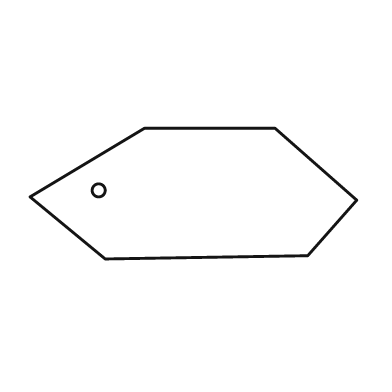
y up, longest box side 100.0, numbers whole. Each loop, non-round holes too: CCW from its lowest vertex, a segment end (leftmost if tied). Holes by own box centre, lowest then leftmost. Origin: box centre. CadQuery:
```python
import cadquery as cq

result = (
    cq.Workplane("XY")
    .moveTo(-27.0, -20.0)
    .lineTo(35.0, -19.0)
    .lineTo(50.0, -2.0)
    .lineTo(25.0, 20.0)
    .lineTo(-15.0, 20.0)
    .lineTo(-50.0, -1.0)
    .close()
    .moveTo(-29.0, 1.0)
    .circle(2.0)
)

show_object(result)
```